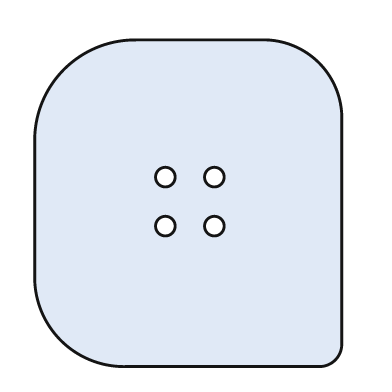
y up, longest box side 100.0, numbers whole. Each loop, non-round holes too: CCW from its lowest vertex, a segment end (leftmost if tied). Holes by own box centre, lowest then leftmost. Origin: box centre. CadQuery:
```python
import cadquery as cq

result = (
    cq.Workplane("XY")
    .moveTo(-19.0, -50.0)
    .lineTo(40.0, -50.0)
    .threePointArc((45.0, -48.0), (47.0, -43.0))
    .lineTo(47.0, 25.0)
    .threePointArc((40.0, 43.0), (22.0, 50.0))
    .lineTo(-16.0, 50.0)
    .threePointArc((-38.0, 41.0), (-47.0, 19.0))
    .lineTo(-47.0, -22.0)
    .threePointArc((-39.0, -42.0), (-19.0, -50.0))
    .close()
    .moveTo(-7.0, -7.0)
    .circle(3.0)
    .moveTo(8.0, -7.0)
    .circle(3.0)
    .moveTo(-7.0, 8.0)
    .circle(3.0)
    .moveTo(8.0, 8.0)
    .circle(3.0)
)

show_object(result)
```